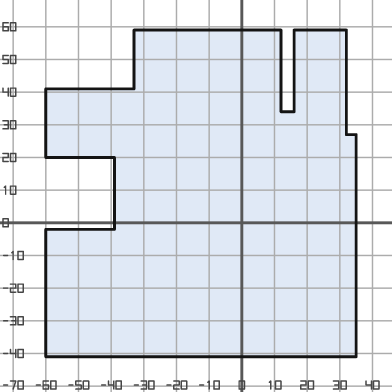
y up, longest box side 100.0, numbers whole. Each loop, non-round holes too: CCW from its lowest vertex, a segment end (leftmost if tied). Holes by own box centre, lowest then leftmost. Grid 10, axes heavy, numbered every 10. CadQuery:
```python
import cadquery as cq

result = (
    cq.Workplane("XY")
    .moveTo(-60.0, -41.0)
    .lineTo(35.0, -41.0)
    .lineTo(35.0, 27.0)
    .lineTo(32.0, 27.0)
    .lineTo(32.0, 59.0)
    .lineTo(16.0, 59.0)
    .lineTo(16.0, 34.0)
    .lineTo(12.0, 34.0)
    .lineTo(12.0, 59.0)
    .lineTo(-33.0, 59.0)
    .lineTo(-33.0, 41.0)
    .lineTo(-60.0, 41.0)
    .lineTo(-60.0, 20.0)
    .lineTo(-39.0, 20.0)
    .lineTo(-39.0, -2.0)
    .lineTo(-60.0, -2.0)
    .close()
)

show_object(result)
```